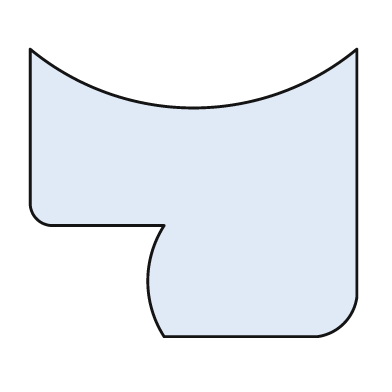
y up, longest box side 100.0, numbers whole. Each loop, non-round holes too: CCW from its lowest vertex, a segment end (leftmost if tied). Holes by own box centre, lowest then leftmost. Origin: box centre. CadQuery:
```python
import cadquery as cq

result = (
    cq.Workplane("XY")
    .moveTo(-9.0, -44.0)
    .lineTo(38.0, -44.0)
    .threePointArc((46.0, -40.0), (50.0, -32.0))
    .lineTo(50.0, 44.0)
    .threePointArc((0.0, 26.0), (-50.0, 44.0))
    .lineTo(-50.0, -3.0)
    .threePointArc((-48.0, -8.0), (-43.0, -10.0))
    .lineTo(-9.0, -10.0)
    .threePointArc((-14.0, -27.0), (-9.0, -44.0))
    .close()
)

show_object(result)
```